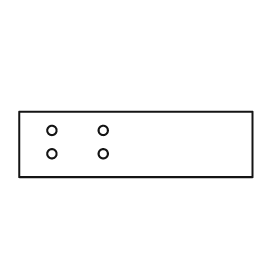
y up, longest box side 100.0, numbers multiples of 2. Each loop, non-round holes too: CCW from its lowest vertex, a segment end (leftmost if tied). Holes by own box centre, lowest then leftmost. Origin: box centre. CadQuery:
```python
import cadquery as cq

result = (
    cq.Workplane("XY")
    .moveTo(-50.0, -14.0)
    .lineTo(50.0, -14.0)
    .lineTo(50.0, 14.0)
    .lineTo(-50.0, 14.0)
    .close()
    .moveTo(-36.0, -4.0)
    .circle(2.0)
    .moveTo(-14.0, -4.0)
    .circle(2.0)
    .moveTo(-36.0, 6.0)
    .circle(2.0)
    .moveTo(-14.0, 6.0)
    .circle(2.0)
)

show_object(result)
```